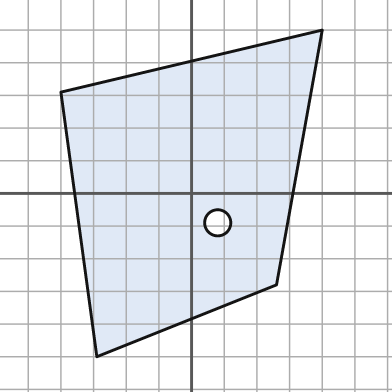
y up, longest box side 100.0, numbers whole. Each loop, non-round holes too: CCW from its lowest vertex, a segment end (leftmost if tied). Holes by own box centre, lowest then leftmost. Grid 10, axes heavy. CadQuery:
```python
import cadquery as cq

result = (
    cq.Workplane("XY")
    .moveTo(-29.0, -50.0)
    .lineTo(26.0, -28.0)
    .lineTo(40.0, 50.0)
    .lineTo(-40.0, 31.0)
    .close()
    .moveTo(8.0, -9.0)
    .circle(4.0)
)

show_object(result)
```